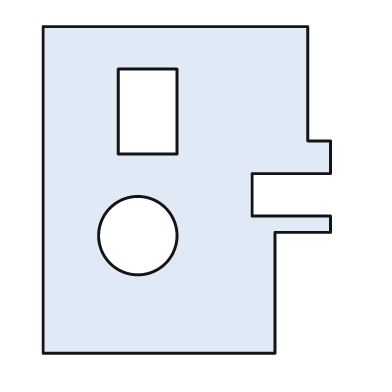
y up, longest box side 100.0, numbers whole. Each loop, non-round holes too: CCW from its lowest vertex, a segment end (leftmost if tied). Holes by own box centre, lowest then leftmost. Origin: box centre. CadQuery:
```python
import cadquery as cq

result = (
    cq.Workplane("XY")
    .moveTo(-44.0, -50.0)
    .lineTo(27.0, -50.0)
    .lineTo(27.0, -13.0)
    .lineTo(44.0, -13.0)
    .lineTo(44.0, -8.0)
    .lineTo(20.0, -8.0)
    .lineTo(20.0, 5.0)
    .lineTo(44.0, 5.0)
    .lineTo(44.0, 15.0)
    .lineTo(37.0, 15.0)
    .lineTo(37.0, 50.0)
    .lineTo(-44.0, 50.0)
    .close()
    .moveTo(-15.0, -14.0)
    .circle(12.0)
    .moveTo(-21.0, 11.0)
    .lineTo(-3.0, 11.0)
    .lineTo(-3.0, 37.0)
    .lineTo(-21.0, 37.0)
    .close()
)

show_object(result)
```